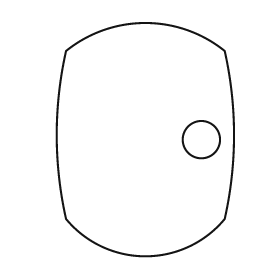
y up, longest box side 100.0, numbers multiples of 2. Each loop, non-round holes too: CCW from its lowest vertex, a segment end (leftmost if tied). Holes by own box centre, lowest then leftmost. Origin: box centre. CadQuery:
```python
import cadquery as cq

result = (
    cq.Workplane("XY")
    .moveTo(-34.0, -34.0)
    .threePointArc((0.0, -50.0), (34.0, -34.0))
    .threePointArc((38.0, 2.0), (34.0, 38.0))
    .threePointArc((0.0, 50.0), (-34.0, 38.0))
    .threePointArc((-38.0, 2.0), (-34.0, -34.0))
    .close()
    .moveTo(24.0, 0.0)
    .circle(8.0)
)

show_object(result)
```